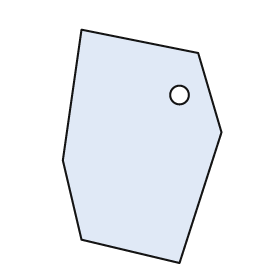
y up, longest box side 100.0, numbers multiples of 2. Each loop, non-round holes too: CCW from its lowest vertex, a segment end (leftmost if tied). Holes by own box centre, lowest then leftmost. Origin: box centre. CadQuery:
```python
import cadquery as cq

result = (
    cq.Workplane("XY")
    .moveTo(16.0, -50.0)
    .lineTo(34.0, 6.0)
    .lineTo(24.0, 40.0)
    .lineTo(-26.0, 50.0)
    .lineTo(-34.0, -6.0)
    .lineTo(-26.0, -40.0)
    .close()
    .moveTo(16.0, 22.0)
    .circle(4.0)
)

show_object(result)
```